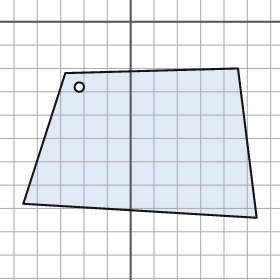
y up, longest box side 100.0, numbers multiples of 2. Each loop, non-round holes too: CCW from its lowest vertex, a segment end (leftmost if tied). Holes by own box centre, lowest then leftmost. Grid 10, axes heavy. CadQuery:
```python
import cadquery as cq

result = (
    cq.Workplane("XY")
    .moveTo(54.0, -84.0)
    .lineTo(46.0, -20.0)
    .lineTo(-28.0, -22.0)
    .lineTo(-46.0, -78.0)
    .close()
    .moveTo(-22.0, -28.0)
    .circle(2.0)
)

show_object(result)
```